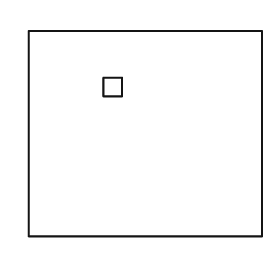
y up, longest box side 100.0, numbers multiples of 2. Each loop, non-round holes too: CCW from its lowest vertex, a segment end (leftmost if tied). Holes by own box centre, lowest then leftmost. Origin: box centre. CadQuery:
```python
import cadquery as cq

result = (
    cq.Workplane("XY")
    .moveTo(-50.0, -44.0)
    .lineTo(50.0, -44.0)
    .lineTo(50.0, 44.0)
    .lineTo(-50.0, 44.0)
    .close()
    .moveTo(-18.0, 16.0)
    .lineTo(-10.0, 16.0)
    .lineTo(-10.0, 24.0)
    .lineTo(-18.0, 24.0)
    .close()
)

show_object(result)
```